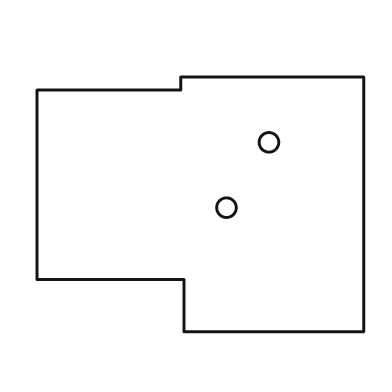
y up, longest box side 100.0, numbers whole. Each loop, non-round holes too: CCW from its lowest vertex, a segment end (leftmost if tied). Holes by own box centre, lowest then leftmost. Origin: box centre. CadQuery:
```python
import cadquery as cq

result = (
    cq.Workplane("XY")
    .moveTo(-5.0, -39.0)
    .lineTo(50.0, -39.0)
    .lineTo(50.0, 39.0)
    .lineTo(-6.0, 39.0)
    .lineTo(-6.0, 35.0)
    .lineTo(-50.0, 35.0)
    .lineTo(-50.0, -23.0)
    .lineTo(-5.0, -23.0)
    .close()
    .moveTo(8.0, -1.0)
    .circle(3.0)
    .moveTo(21.0, 19.0)
    .circle(3.0)
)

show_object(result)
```